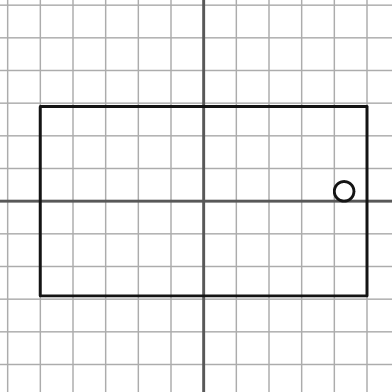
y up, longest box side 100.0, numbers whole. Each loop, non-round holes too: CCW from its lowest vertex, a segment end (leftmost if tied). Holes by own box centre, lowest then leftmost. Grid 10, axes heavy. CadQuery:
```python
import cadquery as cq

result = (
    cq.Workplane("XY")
    .moveTo(-50.0, -29.0)
    .lineTo(50.0, -29.0)
    .lineTo(50.0, 29.0)
    .lineTo(-50.0, 29.0)
    .close()
    .moveTo(43.0, 3.0)
    .circle(3.0)
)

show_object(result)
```